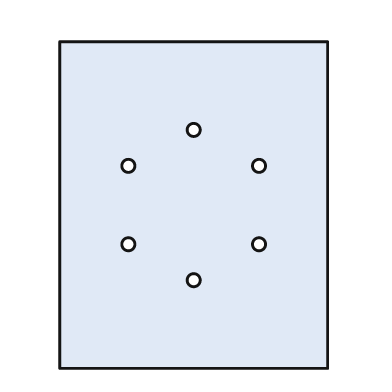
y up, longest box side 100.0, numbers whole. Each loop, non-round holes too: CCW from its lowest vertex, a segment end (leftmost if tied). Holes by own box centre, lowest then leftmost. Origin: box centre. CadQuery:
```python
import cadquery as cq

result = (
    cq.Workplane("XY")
    .moveTo(-41.0, -50.0)
    .lineTo(41.0, -50.0)
    .lineTo(41.0, 50.0)
    .lineTo(-41.0, 50.0)
    .close()
    .moveTo(0.0, -23.0)
    .circle(2.0)
    .moveTo(-20.0, -12.0)
    .circle(2.0)
    .moveTo(20.0, -12.0)
    .circle(2.0)
    .moveTo(-20.0, 12.0)
    .circle(2.0)
    .moveTo(20.0, 12.0)
    .circle(2.0)
    .moveTo(0.0, 23.0)
    .circle(2.0)
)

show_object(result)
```